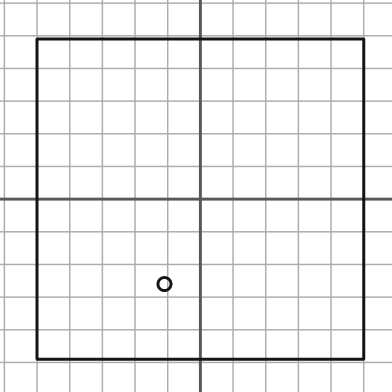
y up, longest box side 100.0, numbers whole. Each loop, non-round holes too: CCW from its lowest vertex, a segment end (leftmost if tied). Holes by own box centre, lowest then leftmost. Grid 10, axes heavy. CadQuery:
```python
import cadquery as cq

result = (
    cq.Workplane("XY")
    .moveTo(-50.0, -49.0)
    .lineTo(50.0, -49.0)
    .lineTo(50.0, 49.0)
    .lineTo(-50.0, 49.0)
    .close()
    .moveTo(-11.0, -26.0)
    .circle(2.0)
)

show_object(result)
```